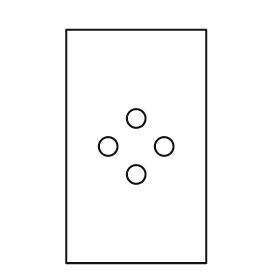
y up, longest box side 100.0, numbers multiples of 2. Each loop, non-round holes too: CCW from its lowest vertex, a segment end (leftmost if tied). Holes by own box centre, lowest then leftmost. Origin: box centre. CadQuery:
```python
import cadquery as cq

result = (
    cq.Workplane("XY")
    .moveTo(-30.0, -50.0)
    .lineTo(30.0, -50.0)
    .lineTo(30.0, 50.0)
    .lineTo(-30.0, 50.0)
    .close()
    .moveTo(0.0, -12.0)
    .circle(4.0)
    .moveTo(-12.0, 0.0)
    .circle(4.0)
    .moveTo(12.0, 0.0)
    .circle(4.0)
    .moveTo(0.0, 12.0)
    .circle(4.0)
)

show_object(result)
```